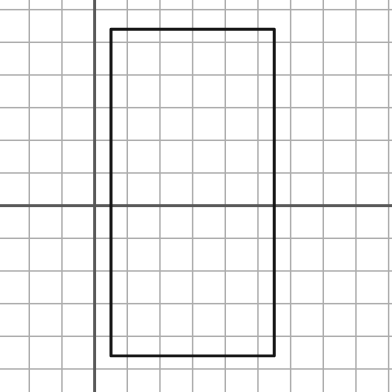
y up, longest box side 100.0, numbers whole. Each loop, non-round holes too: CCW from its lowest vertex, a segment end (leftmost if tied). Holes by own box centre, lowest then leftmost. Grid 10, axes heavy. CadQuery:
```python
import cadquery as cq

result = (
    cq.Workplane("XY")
    .moveTo(5.0, -46.0)
    .lineTo(55.0, -46.0)
    .lineTo(55.0, 54.0)
    .lineTo(5.0, 54.0)
    .close()
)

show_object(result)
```